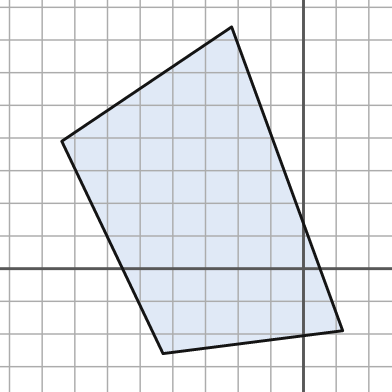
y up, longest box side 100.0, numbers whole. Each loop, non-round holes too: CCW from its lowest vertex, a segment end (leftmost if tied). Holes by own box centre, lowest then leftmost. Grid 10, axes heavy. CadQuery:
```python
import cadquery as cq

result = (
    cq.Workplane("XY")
    .moveTo(-43.0, -26.0)
    .lineTo(12.0, -19.0)
    .lineTo(-22.0, 74.0)
    .lineTo(-74.0, 39.0)
    .close()
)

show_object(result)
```